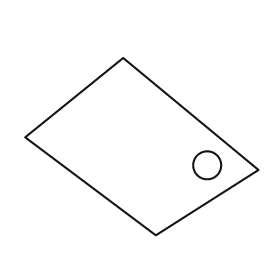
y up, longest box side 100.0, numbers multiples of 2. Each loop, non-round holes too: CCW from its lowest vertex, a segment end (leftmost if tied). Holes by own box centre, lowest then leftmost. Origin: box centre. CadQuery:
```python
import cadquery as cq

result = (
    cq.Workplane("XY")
    .moveTo(6.0, -38.0)
    .lineTo(50.0, -10.0)
    .lineTo(-8.0, 38.0)
    .lineTo(-50.0, 4.0)
    .close()
    .moveTo(28.0, -8.0)
    .circle(6.0)
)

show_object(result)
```